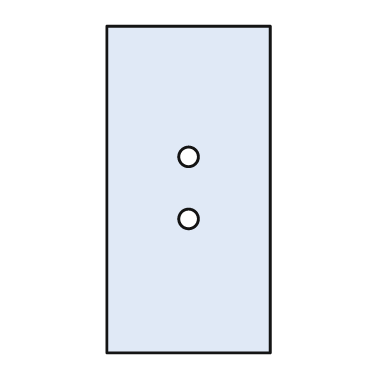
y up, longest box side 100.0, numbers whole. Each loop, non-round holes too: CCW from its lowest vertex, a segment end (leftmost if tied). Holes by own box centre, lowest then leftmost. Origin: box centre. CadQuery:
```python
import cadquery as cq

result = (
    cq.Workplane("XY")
    .moveTo(-25.0, -50.0)
    .lineTo(25.0, -50.0)
    .lineTo(25.0, 50.0)
    .lineTo(-25.0, 50.0)
    .close()
    .moveTo(0.0, -9.0)
    .circle(3.0)
    .moveTo(0.0, 10.0)
    .circle(3.0)
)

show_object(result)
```